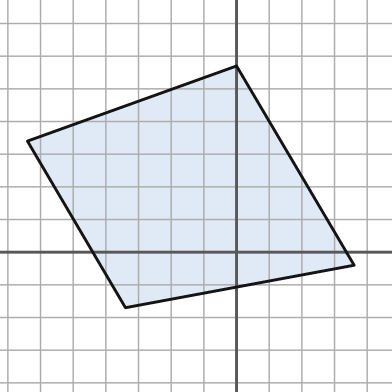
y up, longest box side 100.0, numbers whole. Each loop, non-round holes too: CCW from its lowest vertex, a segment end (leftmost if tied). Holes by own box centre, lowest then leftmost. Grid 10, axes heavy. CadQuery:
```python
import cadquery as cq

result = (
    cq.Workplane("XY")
    .moveTo(-34.0, -17.0)
    .lineTo(36.0, -4.0)
    .lineTo(0.0, 57.0)
    .lineTo(-64.0, 34.0)
    .close()
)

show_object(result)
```